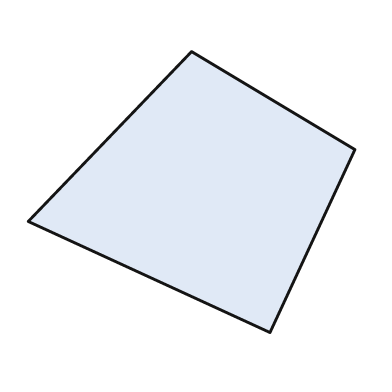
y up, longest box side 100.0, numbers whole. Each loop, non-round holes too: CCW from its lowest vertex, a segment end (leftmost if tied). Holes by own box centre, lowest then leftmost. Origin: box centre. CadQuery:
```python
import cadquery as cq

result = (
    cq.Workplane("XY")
    .moveTo(24.0, -43.0)
    .lineTo(50.0, 13.0)
    .lineTo(0.0, 43.0)
    .lineTo(-50.0, -9.0)
    .close()
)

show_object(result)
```